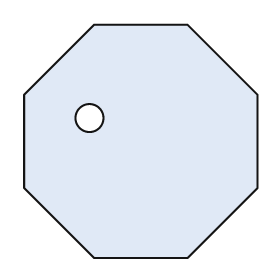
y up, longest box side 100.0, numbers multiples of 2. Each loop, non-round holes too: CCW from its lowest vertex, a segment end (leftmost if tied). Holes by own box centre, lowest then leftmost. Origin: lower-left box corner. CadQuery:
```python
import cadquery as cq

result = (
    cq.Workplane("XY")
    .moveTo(30.0, 0.0)
    .lineTo(70.0, 0.0)
    .lineTo(100.0, 30.0)
    .lineTo(100.0, 70.0)
    .lineTo(70.0, 100.0)
    .lineTo(30.0, 100.0)
    .lineTo(0.0, 70.0)
    .lineTo(0.0, 30.0)
    .close()
    .moveTo(28.0, 60.0)
    .circle(6.0)
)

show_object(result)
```